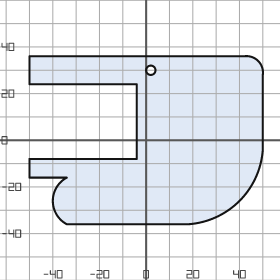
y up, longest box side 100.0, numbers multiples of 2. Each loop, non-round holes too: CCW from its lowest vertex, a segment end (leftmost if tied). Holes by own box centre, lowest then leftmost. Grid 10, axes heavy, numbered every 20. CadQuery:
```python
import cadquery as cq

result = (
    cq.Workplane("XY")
    .moveTo(-34.0, -36.0)
    .lineTo(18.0, -36.0)
    .threePointArc((40.0, -26.0), (50.0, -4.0))
    .lineTo(50.0, 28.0)
    .threePointArc((48.0, 34.0), (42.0, 36.0))
    .lineTo(-50.0, 36.0)
    .lineTo(-50.0, 24.0)
    .lineTo(-4.0, 24.0)
    .lineTo(-4.0, -8.0)
    .lineTo(-50.0, -8.0)
    .lineTo(-50.0, -16.0)
    .lineTo(-34.0, -16.0)
    .threePointArc((-40.0, -26.0), (-34.0, -36.0))
    .close()
    .moveTo(2.0, 30.0)
    .circle(2.0)
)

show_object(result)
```